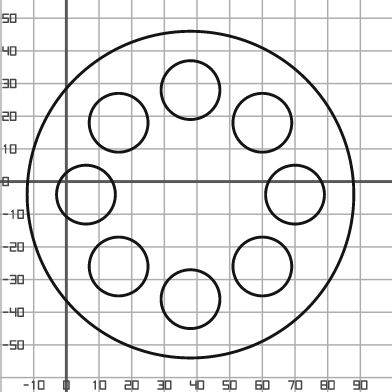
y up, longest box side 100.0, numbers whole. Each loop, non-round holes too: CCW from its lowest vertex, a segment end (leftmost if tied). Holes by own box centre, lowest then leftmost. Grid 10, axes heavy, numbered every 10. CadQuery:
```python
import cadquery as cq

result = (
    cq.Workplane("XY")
    .moveTo(38.0, -4.0)
    .circle(50.0)
    .moveTo(38.0, -36.0)
    .circle(9.0)
    .moveTo(16.0, -26.0)
    .circle(9.0)
    .moveTo(60.0, -26.0)
    .circle(9.0)
    .moveTo(6.0, -4.0)
    .circle(9.0)
    .moveTo(70.0, -4.0)
    .circle(9.0)
    .moveTo(16.0, 18.0)
    .circle(9.0)
    .moveTo(60.0, 18.0)
    .circle(9.0)
    .moveTo(38.0, 28.0)
    .circle(9.0)
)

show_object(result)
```